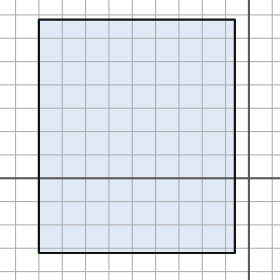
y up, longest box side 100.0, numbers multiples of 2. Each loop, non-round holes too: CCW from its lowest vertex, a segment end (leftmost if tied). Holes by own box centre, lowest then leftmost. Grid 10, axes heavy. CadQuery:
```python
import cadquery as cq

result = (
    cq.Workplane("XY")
    .moveTo(-90.0, -32.0)
    .lineTo(-6.0, -32.0)
    .lineTo(-6.0, 68.0)
    .lineTo(-90.0, 68.0)
    .close()
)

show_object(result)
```